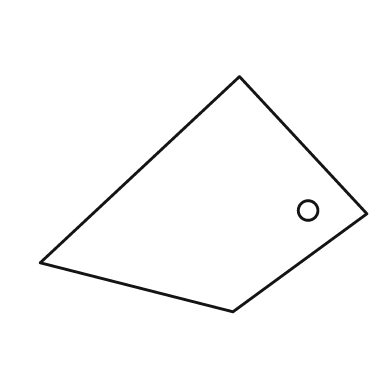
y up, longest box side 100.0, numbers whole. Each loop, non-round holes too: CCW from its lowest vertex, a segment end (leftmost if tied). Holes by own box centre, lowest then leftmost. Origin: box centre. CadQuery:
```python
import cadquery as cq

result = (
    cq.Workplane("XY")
    .moveTo(9.0, -36.0)
    .lineTo(50.0, -6.0)
    .lineTo(11.0, 36.0)
    .lineTo(-50.0, -21.0)
    .close()
    .moveTo(32.0, -5.0)
    .circle(3.0)
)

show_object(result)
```